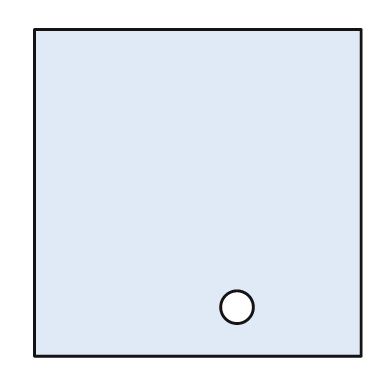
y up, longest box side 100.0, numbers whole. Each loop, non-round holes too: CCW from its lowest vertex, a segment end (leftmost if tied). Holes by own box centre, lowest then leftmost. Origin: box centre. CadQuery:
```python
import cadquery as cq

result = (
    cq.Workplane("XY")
    .moveTo(-50.0, -50.0)
    .lineTo(50.0, -50.0)
    .lineTo(50.0, 50.0)
    .lineTo(-50.0, 50.0)
    .close()
    .moveTo(12.0, -35.0)
    .circle(5.0)
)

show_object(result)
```